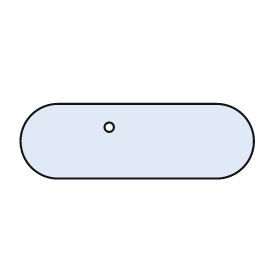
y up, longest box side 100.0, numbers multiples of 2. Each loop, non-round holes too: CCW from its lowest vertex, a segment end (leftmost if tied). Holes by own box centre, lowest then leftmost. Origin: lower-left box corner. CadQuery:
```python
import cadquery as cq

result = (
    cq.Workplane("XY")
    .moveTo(16.0, 0.0)
    .lineTo(84.0, 0.0)
    .threePointArc((100.0, 16.0), (84.0, 32.0))
    .lineTo(16.0, 32.0)
    .threePointArc((0.0, 16.0), (16.0, 0.0))
    .close()
    .moveTo(38.0, 22.0)
    .circle(2.0)
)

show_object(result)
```